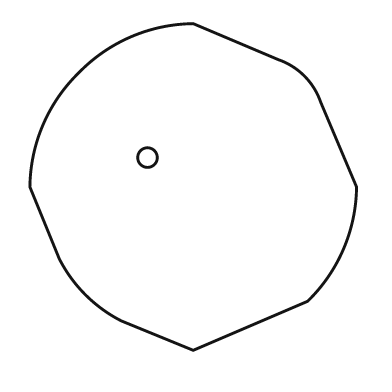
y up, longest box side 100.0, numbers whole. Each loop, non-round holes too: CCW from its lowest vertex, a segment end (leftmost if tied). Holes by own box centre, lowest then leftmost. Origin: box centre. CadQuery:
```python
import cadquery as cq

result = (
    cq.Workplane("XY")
    .moveTo(0.0, -50.0)
    .lineTo(35.0, -35.0)
    .threePointArc((46.0, -19.0), (50.0, 0.0))
    .lineTo(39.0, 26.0)
    .threePointArc((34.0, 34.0), (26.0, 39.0))
    .lineTo(0.0, 50.0)
    .threePointArc((-19.0, 46.0), (-35.0, 35.0))
    .threePointArc((-46.0, 19.0), (-50.0, 0.0))
    .lineTo(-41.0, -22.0)
    .threePointArc((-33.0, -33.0), (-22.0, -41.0))
    .close()
    .moveTo(-14.0, 9.0)
    .circle(3.0)
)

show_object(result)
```